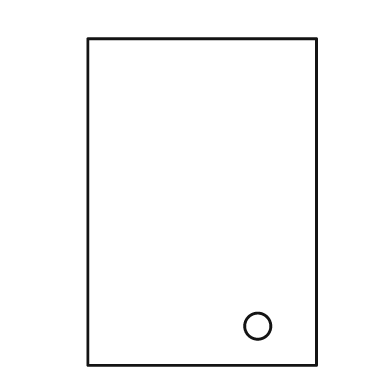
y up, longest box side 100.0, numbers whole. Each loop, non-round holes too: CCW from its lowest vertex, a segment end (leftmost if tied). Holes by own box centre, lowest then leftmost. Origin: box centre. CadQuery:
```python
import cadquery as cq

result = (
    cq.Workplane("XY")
    .moveTo(-35.0, -50.0)
    .lineTo(35.0, -50.0)
    .lineTo(35.0, 50.0)
    .lineTo(-35.0, 50.0)
    .close()
    .moveTo(17.0, -38.0)
    .circle(4.0)
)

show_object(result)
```